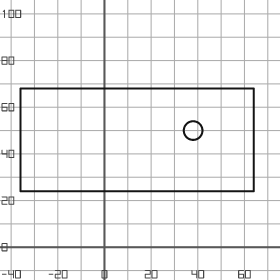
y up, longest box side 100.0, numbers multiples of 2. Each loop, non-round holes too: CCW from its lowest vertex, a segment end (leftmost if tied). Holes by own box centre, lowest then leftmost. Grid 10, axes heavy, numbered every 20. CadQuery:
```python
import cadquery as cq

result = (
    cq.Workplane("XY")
    .moveTo(-36.0, 24.0)
    .lineTo(64.0, 24.0)
    .lineTo(64.0, 68.0)
    .lineTo(-36.0, 68.0)
    .close()
    .moveTo(38.0, 50.0)
    .circle(4.0)
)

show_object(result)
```